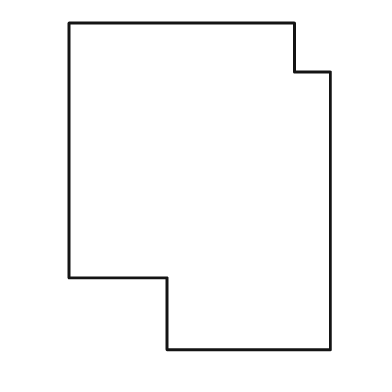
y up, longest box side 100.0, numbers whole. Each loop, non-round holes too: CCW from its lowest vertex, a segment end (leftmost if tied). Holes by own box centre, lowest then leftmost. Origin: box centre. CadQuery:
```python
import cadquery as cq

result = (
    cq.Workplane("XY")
    .moveTo(-10.0, -50.0)
    .lineTo(40.0, -50.0)
    .lineTo(40.0, 35.0)
    .lineTo(29.0, 35.0)
    .lineTo(29.0, 50.0)
    .lineTo(-40.0, 50.0)
    .lineTo(-40.0, -28.0)
    .lineTo(-10.0, -28.0)
    .close()
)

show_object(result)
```